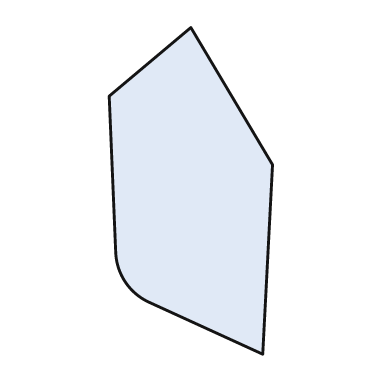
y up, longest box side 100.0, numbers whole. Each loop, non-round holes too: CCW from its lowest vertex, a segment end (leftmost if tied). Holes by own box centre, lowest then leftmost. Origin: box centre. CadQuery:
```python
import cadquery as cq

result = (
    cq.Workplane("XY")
    .moveTo(22.0, -50.0)
    .lineTo(25.0, 8.0)
    .lineTo(0.0, 50.0)
    .lineTo(-25.0, 29.0)
    .lineTo(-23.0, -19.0)
    .threePointArc((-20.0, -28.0), (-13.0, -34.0))
    .close()
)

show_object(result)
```